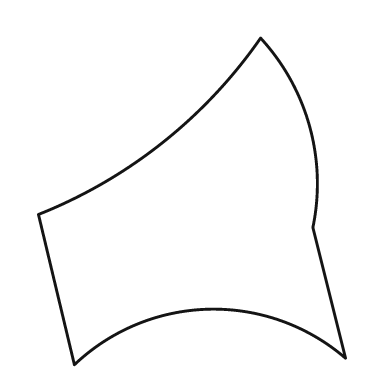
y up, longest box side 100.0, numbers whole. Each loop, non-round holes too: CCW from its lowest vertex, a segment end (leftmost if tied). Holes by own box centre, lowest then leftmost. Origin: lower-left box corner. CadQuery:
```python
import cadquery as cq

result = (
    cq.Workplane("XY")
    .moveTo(11.0, 0.0)
    .threePointArc((52.0, 17.0), (94.0, 2.0))
    .lineTo(84.0, 42.0)
    .threePointArc((83.0, 73.0), (68.0, 100.0))
    .threePointArc((38.0, 68.0), (0.0, 46.0))
    .close()
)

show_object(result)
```